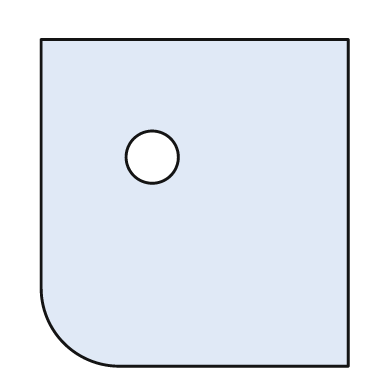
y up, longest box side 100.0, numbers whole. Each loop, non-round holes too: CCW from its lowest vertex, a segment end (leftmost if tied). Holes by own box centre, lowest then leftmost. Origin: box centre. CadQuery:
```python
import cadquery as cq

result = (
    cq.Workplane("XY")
    .moveTo(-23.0, -50.0)
    .lineTo(47.0, -50.0)
    .lineTo(47.0, 50.0)
    .lineTo(-47.0, 50.0)
    .lineTo(-47.0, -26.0)
    .threePointArc((-40.0, -43.0), (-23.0, -50.0))
    .close()
    .moveTo(-13.0, 14.0)
    .circle(8.0)
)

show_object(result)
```